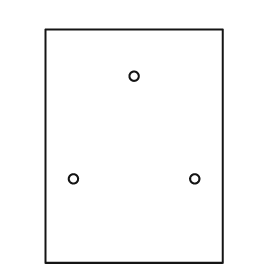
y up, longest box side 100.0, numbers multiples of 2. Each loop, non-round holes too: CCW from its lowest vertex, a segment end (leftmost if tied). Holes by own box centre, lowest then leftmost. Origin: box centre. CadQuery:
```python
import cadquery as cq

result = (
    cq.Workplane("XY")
    .moveTo(-38.0, -50.0)
    .lineTo(38.0, -50.0)
    .lineTo(38.0, 50.0)
    .lineTo(-38.0, 50.0)
    .close()
    .moveTo(-26.0, -14.0)
    .circle(2.0)
    .moveTo(26.0, -14.0)
    .circle(2.0)
    .moveTo(0.0, 30.0)
    .circle(2.0)
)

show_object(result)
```